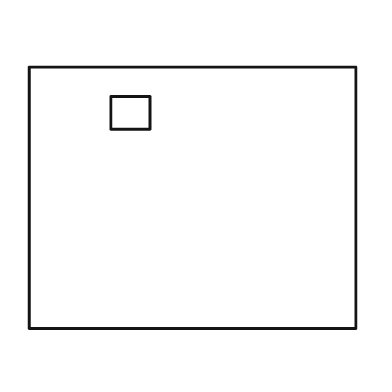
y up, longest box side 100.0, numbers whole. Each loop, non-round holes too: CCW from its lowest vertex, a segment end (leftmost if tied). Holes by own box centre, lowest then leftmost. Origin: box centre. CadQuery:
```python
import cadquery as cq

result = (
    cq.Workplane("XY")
    .moveTo(-50.0, -40.0)
    .lineTo(50.0, -40.0)
    .lineTo(50.0, 40.0)
    .lineTo(-50.0, 40.0)
    .close()
    .moveTo(-25.0, 21.0)
    .lineTo(-13.0, 21.0)
    .lineTo(-13.0, 31.0)
    .lineTo(-25.0, 31.0)
    .close()
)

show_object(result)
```